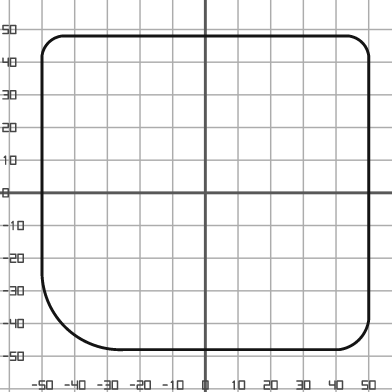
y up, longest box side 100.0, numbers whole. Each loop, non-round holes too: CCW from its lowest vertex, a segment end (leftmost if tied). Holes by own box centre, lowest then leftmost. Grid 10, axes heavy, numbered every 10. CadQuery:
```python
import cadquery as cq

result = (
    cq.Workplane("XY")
    .moveTo(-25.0, -48.0)
    .lineTo(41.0, -48.0)
    .threePointArc((47.0, -45.0), (50.0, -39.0))
    .lineTo(50.0, 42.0)
    .threePointArc((48.0, 46.0), (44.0, 48.0))
    .lineTo(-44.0, 48.0)
    .threePointArc((-48.0, 46.0), (-50.0, 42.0))
    .lineTo(-50.0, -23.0)
    .threePointArc((-43.0, -41.0), (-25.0, -48.0))
    .close()
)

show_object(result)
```